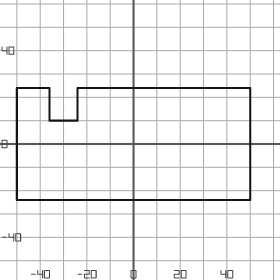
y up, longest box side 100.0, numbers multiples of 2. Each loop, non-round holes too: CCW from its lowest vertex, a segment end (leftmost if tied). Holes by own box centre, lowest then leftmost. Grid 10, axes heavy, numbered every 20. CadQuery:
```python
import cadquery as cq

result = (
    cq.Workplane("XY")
    .moveTo(-50.0, -24.0)
    .lineTo(50.0, -24.0)
    .lineTo(50.0, 24.0)
    .lineTo(-24.0, 24.0)
    .lineTo(-24.0, 10.0)
    .lineTo(-36.0, 10.0)
    .lineTo(-36.0, 24.0)
    .lineTo(-50.0, 24.0)
    .close()
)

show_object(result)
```